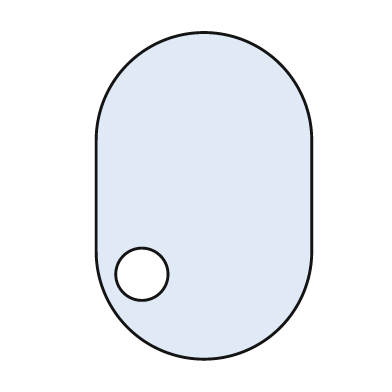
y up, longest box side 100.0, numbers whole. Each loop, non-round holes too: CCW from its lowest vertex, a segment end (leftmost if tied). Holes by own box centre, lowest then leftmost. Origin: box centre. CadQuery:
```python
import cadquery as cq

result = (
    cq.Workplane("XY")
    .moveTo(-33.0, -17.0)
    .threePointArc((0.0, -50.0), (33.0, -17.0))
    .lineTo(33.0, 17.0)
    .threePointArc((0.0, 50.0), (-33.0, 17.0))
    .close()
    .moveTo(-19.0, -24.0)
    .circle(8.0)
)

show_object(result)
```